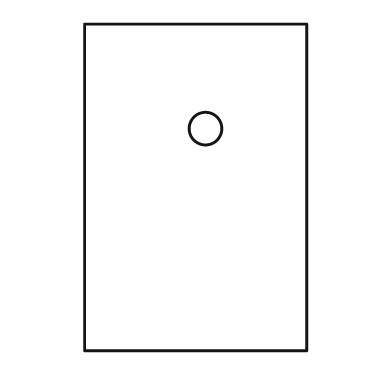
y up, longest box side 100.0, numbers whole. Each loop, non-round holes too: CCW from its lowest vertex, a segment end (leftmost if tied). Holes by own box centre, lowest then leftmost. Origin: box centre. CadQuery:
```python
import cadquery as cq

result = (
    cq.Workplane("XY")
    .moveTo(-34.0, -50.0)
    .lineTo(34.0, -50.0)
    .lineTo(34.0, 50.0)
    .lineTo(-34.0, 50.0)
    .close()
    .moveTo(3.0, 18.0)
    .circle(5.0)
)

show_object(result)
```